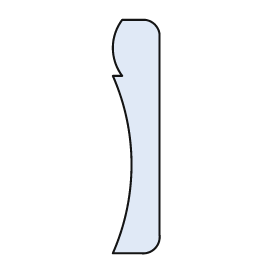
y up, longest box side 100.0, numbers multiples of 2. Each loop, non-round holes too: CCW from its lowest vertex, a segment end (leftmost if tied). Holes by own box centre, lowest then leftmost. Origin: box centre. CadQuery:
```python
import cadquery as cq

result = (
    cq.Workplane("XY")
    .moveTo(-10.0, -50.0)
    .lineTo(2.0, -50.0)
    .threePointArc((8.0, -48.0), (10.0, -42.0))
    .lineTo(10.0, 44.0)
    .threePointArc((8.0, 48.0), (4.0, 50.0))
    .lineTo(-6.0, 50.0)
    .threePointArc((-10.0, 38.0), (-6.0, 26.0))
    .lineTo(-10.0, 26.0)
    .threePointArc((-2.0, -12.0), (-10.0, -50.0))
    .close()
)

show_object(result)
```